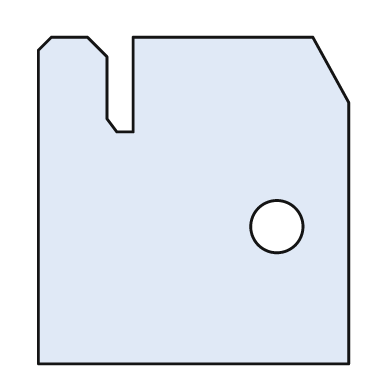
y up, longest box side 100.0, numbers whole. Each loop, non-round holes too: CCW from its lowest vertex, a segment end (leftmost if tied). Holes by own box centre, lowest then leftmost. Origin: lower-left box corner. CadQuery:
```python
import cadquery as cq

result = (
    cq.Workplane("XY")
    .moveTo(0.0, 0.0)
    .lineTo(95.0, 0.0)
    .lineTo(95.0, 80.0)
    .lineTo(84.0, 100.0)
    .lineTo(29.0, 100.0)
    .lineTo(29.0, 71.0)
    .lineTo(24.0, 71.0)
    .lineTo(21.0, 75.0)
    .lineTo(21.0, 94.0)
    .lineTo(15.0, 100.0)
    .lineTo(4.0, 100.0)
    .lineTo(0.0, 96.0)
    .close()
    .moveTo(73.0, 42.0)
    .circle(8.0)
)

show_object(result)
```